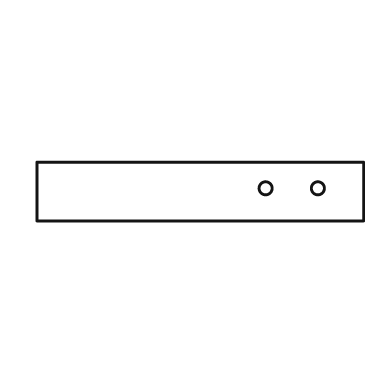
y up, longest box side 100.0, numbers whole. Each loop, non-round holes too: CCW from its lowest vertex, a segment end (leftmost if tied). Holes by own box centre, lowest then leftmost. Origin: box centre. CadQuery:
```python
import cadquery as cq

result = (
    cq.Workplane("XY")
    .moveTo(-50.0, -9.0)
    .lineTo(50.0, -9.0)
    .lineTo(50.0, 9.0)
    .lineTo(-50.0, 9.0)
    .close()
    .moveTo(20.0, 1.0)
    .circle(2.0)
    .moveTo(36.0, 1.0)
    .circle(2.0)
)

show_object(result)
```